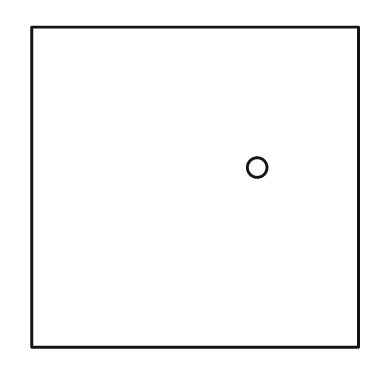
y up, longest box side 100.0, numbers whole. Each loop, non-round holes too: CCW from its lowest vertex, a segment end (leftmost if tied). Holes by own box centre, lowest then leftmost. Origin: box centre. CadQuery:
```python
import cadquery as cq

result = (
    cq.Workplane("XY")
    .moveTo(-50.0, -49.0)
    .lineTo(50.0, -49.0)
    .lineTo(50.0, 49.0)
    .lineTo(-50.0, 49.0)
    .close()
    .moveTo(19.0, 6.0)
    .circle(3.0)
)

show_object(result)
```